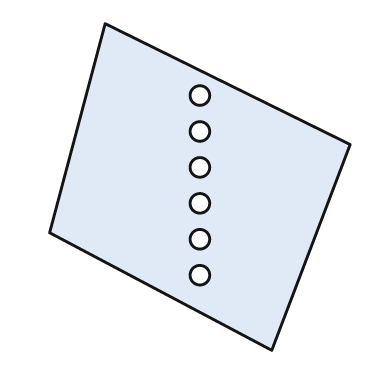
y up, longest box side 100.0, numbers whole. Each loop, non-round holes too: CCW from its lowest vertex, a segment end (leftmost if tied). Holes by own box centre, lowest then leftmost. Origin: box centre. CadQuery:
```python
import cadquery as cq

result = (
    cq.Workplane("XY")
    .moveTo(22.0, -50.0)
    .lineTo(46.0, 13.0)
    .lineTo(-29.0, 50.0)
    .lineTo(-46.0, -14.0)
    .close()
    .moveTo(0.0, -27.0)
    .circle(3.0)
    .moveTo(0.0, -16.0)
    .circle(3.0)
    .moveTo(0.0, -5.0)
    .circle(3.0)
    .moveTo(0.0, 6.0)
    .circle(3.0)
    .moveTo(0.0, 17.0)
    .circle(3.0)
    .moveTo(0.0, 28.0)
    .circle(3.0)
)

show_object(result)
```